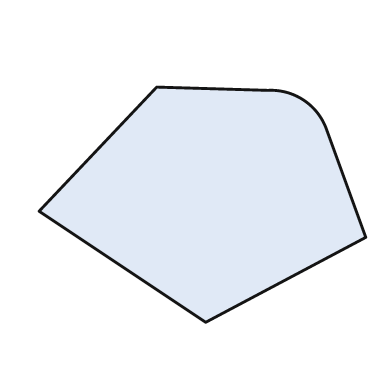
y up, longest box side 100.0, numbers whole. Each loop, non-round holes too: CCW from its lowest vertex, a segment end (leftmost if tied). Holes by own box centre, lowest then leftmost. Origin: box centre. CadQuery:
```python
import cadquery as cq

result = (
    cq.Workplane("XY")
    .moveTo(1.0, -36.0)
    .lineTo(50.0, -10.0)
    .lineTo(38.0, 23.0)
    .threePointArc((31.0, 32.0), (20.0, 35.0))
    .lineTo(-14.0, 36.0)
    .lineTo(-50.0, -2.0)
    .close()
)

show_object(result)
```